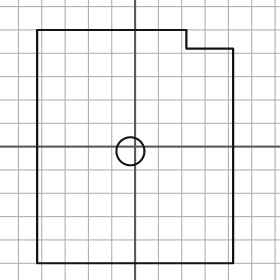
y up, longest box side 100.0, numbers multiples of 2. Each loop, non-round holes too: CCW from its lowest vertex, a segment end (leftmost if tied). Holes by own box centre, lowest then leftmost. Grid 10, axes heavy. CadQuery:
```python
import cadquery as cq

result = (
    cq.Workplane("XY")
    .moveTo(-42.0, -50.0)
    .lineTo(42.0, -50.0)
    .lineTo(42.0, 42.0)
    .lineTo(22.0, 42.0)
    .lineTo(22.0, 50.0)
    .lineTo(-42.0, 50.0)
    .close()
    .moveTo(-2.0, -2.0)
    .circle(6.0)
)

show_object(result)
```